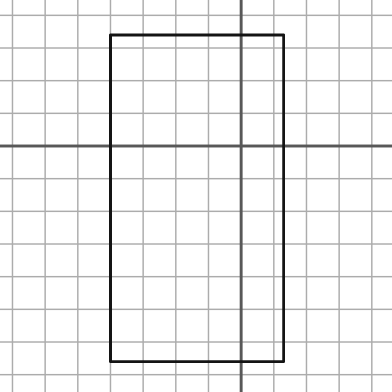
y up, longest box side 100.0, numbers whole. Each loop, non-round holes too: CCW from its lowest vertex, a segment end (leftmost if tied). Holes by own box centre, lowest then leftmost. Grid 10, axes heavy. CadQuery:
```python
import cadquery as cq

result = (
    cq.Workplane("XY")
    .moveTo(-40.0, -66.0)
    .lineTo(13.0, -66.0)
    .lineTo(13.0, 34.0)
    .lineTo(-40.0, 34.0)
    .close()
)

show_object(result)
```